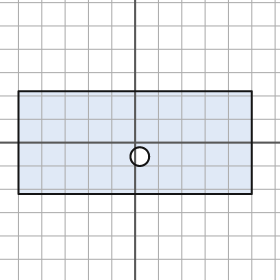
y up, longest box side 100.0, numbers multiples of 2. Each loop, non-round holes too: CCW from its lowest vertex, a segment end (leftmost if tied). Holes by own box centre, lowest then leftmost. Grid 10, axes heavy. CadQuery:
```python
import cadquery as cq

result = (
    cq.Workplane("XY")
    .moveTo(-50.0, -22.0)
    .lineTo(50.0, -22.0)
    .lineTo(50.0, 22.0)
    .lineTo(-50.0, 22.0)
    .close()
    .moveTo(2.0, -6.0)
    .circle(4.0)
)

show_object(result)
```